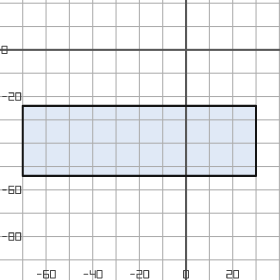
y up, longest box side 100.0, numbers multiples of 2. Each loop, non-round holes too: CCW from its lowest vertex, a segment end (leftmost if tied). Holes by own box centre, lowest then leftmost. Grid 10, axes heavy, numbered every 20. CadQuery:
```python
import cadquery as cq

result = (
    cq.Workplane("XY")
    .moveTo(-70.0, -54.0)
    .lineTo(30.0, -54.0)
    .lineTo(30.0, -24.0)
    .lineTo(-70.0, -24.0)
    .close()
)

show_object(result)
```